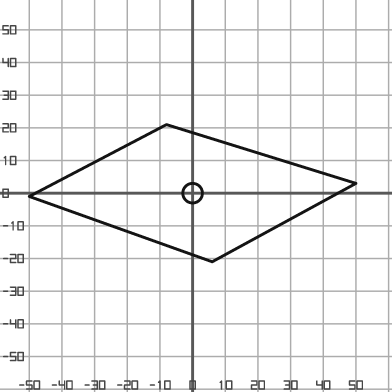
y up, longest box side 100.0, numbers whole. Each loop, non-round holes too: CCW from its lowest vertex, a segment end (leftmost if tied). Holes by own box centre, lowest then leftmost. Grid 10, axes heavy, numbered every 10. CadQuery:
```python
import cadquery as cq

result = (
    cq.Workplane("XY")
    .moveTo(6.0, -21.0)
    .lineTo(50.0, 3.0)
    .lineTo(-8.0, 21.0)
    .lineTo(-50.0, -1.0)
    .close()
    .moveTo(0.0, 0.0)
    .circle(3.0)
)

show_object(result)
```